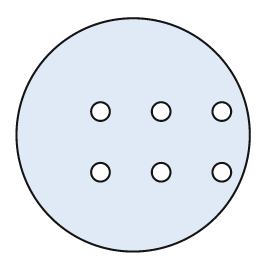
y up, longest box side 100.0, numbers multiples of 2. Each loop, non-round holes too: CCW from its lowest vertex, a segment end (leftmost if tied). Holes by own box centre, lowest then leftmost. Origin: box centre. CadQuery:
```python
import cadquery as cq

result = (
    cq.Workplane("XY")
    .moveTo(0.0, 0.0)
    .circle(50.0)
    .moveTo(-14.0, -16.0)
    .circle(4.0)
    .moveTo(12.0, -16.0)
    .circle(4.0)
    .moveTo(38.0, -16.0)
    .circle(4.0)
    .moveTo(-14.0, 10.0)
    .circle(4.0)
    .moveTo(12.0, 10.0)
    .circle(4.0)
    .moveTo(38.0, 10.0)
    .circle(4.0)
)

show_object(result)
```